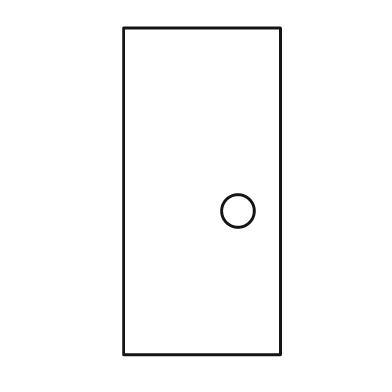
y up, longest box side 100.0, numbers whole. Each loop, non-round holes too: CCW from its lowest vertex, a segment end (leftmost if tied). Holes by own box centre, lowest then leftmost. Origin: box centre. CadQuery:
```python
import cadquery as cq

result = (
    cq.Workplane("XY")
    .moveTo(-24.0, -50.0)
    .lineTo(24.0, -50.0)
    .lineTo(24.0, 50.0)
    .lineTo(-24.0, 50.0)
    .close()
    .moveTo(11.0, -6.0)
    .circle(5.0)
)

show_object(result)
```